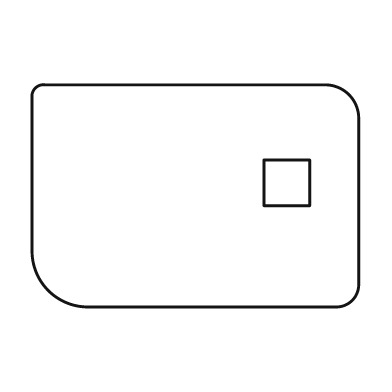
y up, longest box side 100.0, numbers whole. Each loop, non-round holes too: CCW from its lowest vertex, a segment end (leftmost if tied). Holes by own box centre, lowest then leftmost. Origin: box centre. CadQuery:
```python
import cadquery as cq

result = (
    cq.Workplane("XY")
    .moveTo(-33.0, -34.0)
    .lineTo(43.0, -34.0)
    .threePointArc((48.0, -32.0), (50.0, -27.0))
    .lineTo(50.0, 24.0)
    .threePointArc((47.0, 31.0), (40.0, 34.0))
    .lineTo(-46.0, 34.0)
    .threePointArc((-49.0, 33.0), (-50.0, 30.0))
    .lineTo(-50.0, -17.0)
    .threePointArc((-45.0, -29.0), (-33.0, -34.0))
    .close()
    .moveTo(21.0, -3.0)
    .lineTo(35.0, -3.0)
    .lineTo(35.0, 11.0)
    .lineTo(21.0, 11.0)
    .close()
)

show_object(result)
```